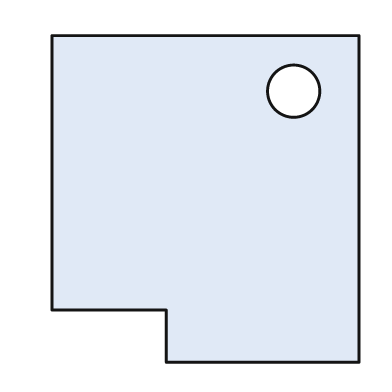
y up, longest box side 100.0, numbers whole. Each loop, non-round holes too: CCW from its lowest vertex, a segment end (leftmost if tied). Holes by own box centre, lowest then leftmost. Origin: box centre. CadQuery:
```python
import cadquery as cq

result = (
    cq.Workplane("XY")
    .moveTo(-12.0, -50.0)
    .lineTo(47.0, -50.0)
    .lineTo(47.0, 50.0)
    .lineTo(-47.0, 50.0)
    .lineTo(-47.0, -34.0)
    .lineTo(-12.0, -34.0)
    .close()
    .moveTo(27.0, 33.0)
    .circle(8.0)
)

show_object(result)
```